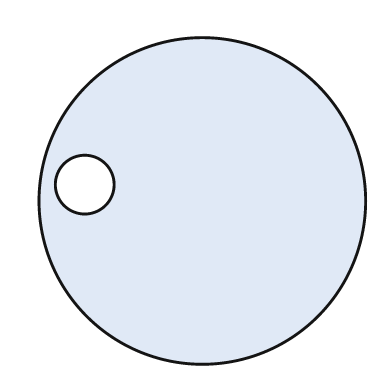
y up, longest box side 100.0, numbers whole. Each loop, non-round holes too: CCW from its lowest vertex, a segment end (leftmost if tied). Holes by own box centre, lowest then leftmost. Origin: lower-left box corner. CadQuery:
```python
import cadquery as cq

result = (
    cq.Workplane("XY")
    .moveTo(50.0, 50.0)
    .circle(50.0)
    .moveTo(14.0, 55.0)
    .circle(9.0)
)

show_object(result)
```